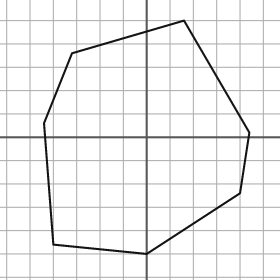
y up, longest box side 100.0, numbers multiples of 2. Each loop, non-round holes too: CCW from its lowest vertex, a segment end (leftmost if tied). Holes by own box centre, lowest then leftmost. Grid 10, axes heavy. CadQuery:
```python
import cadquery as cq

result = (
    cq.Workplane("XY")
    .moveTo(0.0, -50.0)
    .lineTo(40.0, -24.0)
    .lineTo(44.0, 2.0)
    .lineTo(16.0, 50.0)
    .lineTo(-32.0, 36.0)
    .lineTo(-44.0, 6.0)
    .lineTo(-40.0, -46.0)
    .close()
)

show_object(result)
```